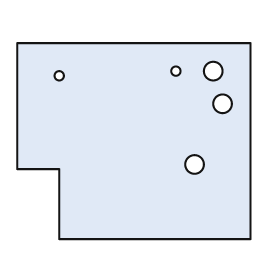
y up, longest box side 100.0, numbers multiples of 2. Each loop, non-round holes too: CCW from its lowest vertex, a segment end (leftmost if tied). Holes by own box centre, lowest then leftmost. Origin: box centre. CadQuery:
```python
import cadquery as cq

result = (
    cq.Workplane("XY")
    .moveTo(-32.0, -42.0)
    .lineTo(50.0, -42.0)
    .lineTo(50.0, 42.0)
    .lineTo(-50.0, 42.0)
    .lineTo(-50.0, -12.0)
    .lineTo(-32.0, -12.0)
    .close()
    .moveTo(26.0, -10.0)
    .circle(4.0)
    .moveTo(38.0, 16.0)
    .circle(4.0)
    .moveTo(-32.0, 28.0)
    .circle(2.0)
    .moveTo(18.0, 30.0)
    .circle(2.0)
    .moveTo(34.0, 30.0)
    .circle(4.0)
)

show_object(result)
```